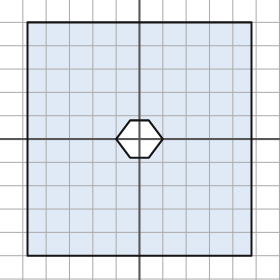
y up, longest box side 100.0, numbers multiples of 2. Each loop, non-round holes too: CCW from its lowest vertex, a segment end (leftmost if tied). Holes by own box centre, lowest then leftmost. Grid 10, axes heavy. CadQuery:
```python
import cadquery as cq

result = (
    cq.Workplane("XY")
    .moveTo(-48.0, -50.0)
    .lineTo(48.0, -50.0)
    .lineTo(48.0, 50.0)
    .lineTo(-48.0, 50.0)
    .close()
    .moveTo(-4.0, -8.0)
    .lineTo(4.0, -8.0)
    .lineTo(10.0, 0.0)
    .lineTo(4.0, 8.0)
    .lineTo(-4.0, 8.0)
    .lineTo(-10.0, 0.0)
    .close()
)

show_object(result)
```